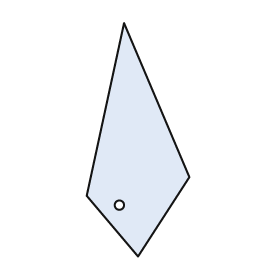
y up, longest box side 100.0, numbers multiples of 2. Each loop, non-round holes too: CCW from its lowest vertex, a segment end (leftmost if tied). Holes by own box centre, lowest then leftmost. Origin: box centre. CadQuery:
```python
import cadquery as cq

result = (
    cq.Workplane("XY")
    .moveTo(0.0, -50.0)
    .lineTo(22.0, -16.0)
    .lineTo(-6.0, 50.0)
    .lineTo(-22.0, -24.0)
    .close()
    .moveTo(-8.0, -28.0)
    .circle(2.0)
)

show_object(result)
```